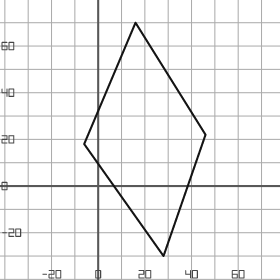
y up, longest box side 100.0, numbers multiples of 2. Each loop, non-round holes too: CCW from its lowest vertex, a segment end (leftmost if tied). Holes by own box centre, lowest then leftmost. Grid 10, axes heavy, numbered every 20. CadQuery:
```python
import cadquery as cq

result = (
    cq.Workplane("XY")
    .moveTo(28.0, -30.0)
    .lineTo(46.0, 22.0)
    .lineTo(16.0, 70.0)
    .lineTo(-6.0, 18.0)
    .close()
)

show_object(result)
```